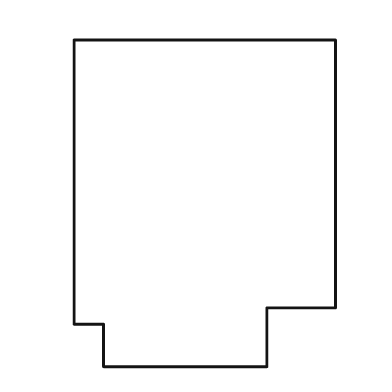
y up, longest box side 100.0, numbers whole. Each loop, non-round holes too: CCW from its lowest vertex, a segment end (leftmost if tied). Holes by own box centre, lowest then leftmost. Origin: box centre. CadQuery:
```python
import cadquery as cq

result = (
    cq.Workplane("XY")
    .moveTo(-31.0, -50.0)
    .lineTo(19.0, -50.0)
    .lineTo(19.0, -32.0)
    .lineTo(40.0, -32.0)
    .lineTo(40.0, 50.0)
    .lineTo(-40.0, 50.0)
    .lineTo(-40.0, -37.0)
    .lineTo(-31.0, -37.0)
    .close()
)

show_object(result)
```